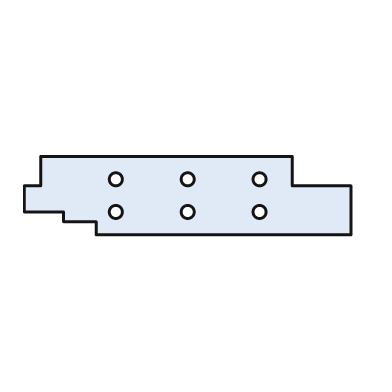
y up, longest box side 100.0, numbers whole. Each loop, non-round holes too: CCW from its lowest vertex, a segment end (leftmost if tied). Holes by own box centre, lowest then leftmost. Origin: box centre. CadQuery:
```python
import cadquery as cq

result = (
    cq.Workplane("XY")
    .moveTo(-28.0, -12.0)
    .lineTo(50.0, -12.0)
    .lineTo(50.0, 3.0)
    .lineTo(32.0, 3.0)
    .lineTo(32.0, 12.0)
    .lineTo(-45.0, 12.0)
    .lineTo(-45.0, 3.0)
    .lineTo(-50.0, 3.0)
    .lineTo(-50.0, -5.0)
    .lineTo(-38.0, -5.0)
    .lineTo(-38.0, -8.0)
    .lineTo(-28.0, -8.0)
    .close()
    .moveTo(-22.0, -5.0)
    .circle(2.0)
    .moveTo(0.0, -5.0)
    .circle(2.0)
    .moveTo(22.0, -5.0)
    .circle(2.0)
    .moveTo(-22.0, 5.0)
    .circle(2.0)
    .moveTo(0.0, 5.0)
    .circle(2.0)
    .moveTo(22.0, 5.0)
    .circle(2.0)
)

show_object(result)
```